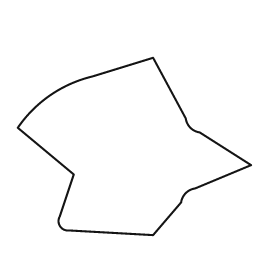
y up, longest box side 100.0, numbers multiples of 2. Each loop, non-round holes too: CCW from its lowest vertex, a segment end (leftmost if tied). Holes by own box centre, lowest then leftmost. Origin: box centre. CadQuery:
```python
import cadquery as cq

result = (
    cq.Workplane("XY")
    .moveTo(8.0, -38.0)
    .lineTo(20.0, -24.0)
    .threePointArc((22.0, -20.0), (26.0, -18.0))
    .lineTo(50.0, -8.0)
    .lineTo(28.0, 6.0)
    .threePointArc((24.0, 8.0), (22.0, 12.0))
    .lineTo(8.0, 38.0)
    .lineTo(-18.0, 30.0)
    .threePointArc((-36.0, 22.0), (-50.0, 8.0))
    .lineTo(-26.0, -12.0)
    .lineTo(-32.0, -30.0)
    .threePointArc((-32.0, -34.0), (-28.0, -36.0))
    .close()
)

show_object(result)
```